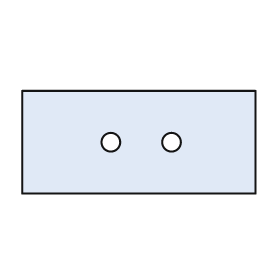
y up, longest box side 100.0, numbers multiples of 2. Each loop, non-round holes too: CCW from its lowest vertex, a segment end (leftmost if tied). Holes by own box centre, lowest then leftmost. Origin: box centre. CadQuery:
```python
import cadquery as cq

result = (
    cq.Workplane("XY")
    .moveTo(-50.0, -22.0)
    .lineTo(50.0, -22.0)
    .lineTo(50.0, 22.0)
    .lineTo(-50.0, 22.0)
    .close()
    .moveTo(-12.0, 0.0)
    .circle(4.0)
    .moveTo(14.0, 0.0)
    .circle(4.0)
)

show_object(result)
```